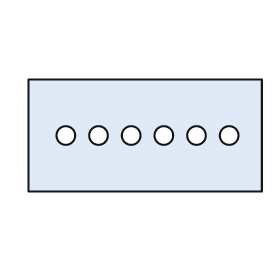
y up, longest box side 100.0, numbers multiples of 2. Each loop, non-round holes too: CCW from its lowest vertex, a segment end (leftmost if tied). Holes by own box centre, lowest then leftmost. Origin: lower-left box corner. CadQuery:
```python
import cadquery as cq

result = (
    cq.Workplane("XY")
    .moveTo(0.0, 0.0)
    .lineTo(100.0, 0.0)
    .lineTo(100.0, 48.0)
    .lineTo(0.0, 48.0)
    .close()
    .moveTo(16.0, 24.0)
    .circle(4.0)
    .moveTo(30.0, 24.0)
    .circle(4.0)
    .moveTo(44.0, 24.0)
    .circle(4.0)
    .moveTo(58.0, 24.0)
    .circle(4.0)
    .moveTo(72.0, 24.0)
    .circle(4.0)
    .moveTo(86.0, 24.0)
    .circle(4.0)
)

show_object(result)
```